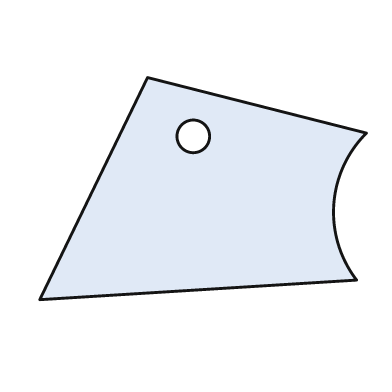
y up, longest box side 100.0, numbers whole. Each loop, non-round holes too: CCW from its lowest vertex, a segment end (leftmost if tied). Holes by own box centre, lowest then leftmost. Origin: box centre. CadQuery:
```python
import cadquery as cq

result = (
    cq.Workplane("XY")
    .moveTo(-50.0, -34.0)
    .lineTo(47.0, -28.0)
    .threePointArc((40.0, -5.0), (50.0, 17.0))
    .lineTo(-17.0, 34.0)
    .close()
    .moveTo(-3.0, 16.0)
    .circle(5.0)
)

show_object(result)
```